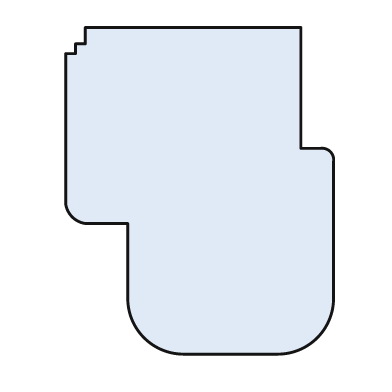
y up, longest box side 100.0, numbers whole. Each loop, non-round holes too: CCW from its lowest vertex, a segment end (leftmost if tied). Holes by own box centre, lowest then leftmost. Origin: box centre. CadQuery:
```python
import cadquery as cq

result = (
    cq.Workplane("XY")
    .moveTo(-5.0, -50.0)
    .lineTo(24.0, -50.0)
    .threePointArc((36.0, -45.0), (41.0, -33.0))
    .lineTo(41.0, 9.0)
    .threePointArc((40.0, 12.0), (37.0, 13.0))
    .lineTo(31.0, 13.0)
    .lineTo(31.0, 50.0)
    .lineTo(-35.0, 50.0)
    .lineTo(-35.0, 45.0)
    .lineTo(-38.0, 45.0)
    .lineTo(-38.0, 42.0)
    .lineTo(-41.0, 42.0)
    .lineTo(-41.0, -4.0)
    .threePointArc((-39.0, -8.0), (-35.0, -10.0))
    .lineTo(-22.0, -10.0)
    .lineTo(-22.0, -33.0)
    .threePointArc((-17.0, -45.0), (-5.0, -50.0))
    .close()
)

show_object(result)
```